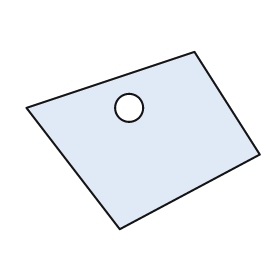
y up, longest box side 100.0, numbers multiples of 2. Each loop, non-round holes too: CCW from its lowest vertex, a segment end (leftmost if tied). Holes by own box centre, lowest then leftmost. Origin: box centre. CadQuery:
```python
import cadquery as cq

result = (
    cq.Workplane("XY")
    .moveTo(-10.0, -38.0)
    .lineTo(50.0, -6.0)
    .lineTo(22.0, 38.0)
    .lineTo(-50.0, 14.0)
    .close()
    .moveTo(-6.0, 14.0)
    .circle(6.0)
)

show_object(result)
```